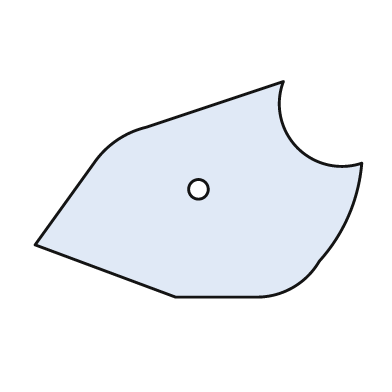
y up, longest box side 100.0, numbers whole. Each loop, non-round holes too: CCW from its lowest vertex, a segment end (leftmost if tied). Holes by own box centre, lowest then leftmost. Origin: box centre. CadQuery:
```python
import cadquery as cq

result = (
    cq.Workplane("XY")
    .moveTo(-7.0, -33.0)
    .lineTo(18.0, -33.0)
    .threePointArc((29.0, -30.0), (37.0, -22.0))
    .threePointArc((46.0, -8.0), (50.0, 8.0))
    .threePointArc((30.0, 13.0), (26.0, 33.0))
    .lineTo(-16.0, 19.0)
    .threePointArc((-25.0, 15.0), (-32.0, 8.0))
    .lineTo(-50.0, -17.0)
    .close()
    .moveTo(0.0, 0.0)
    .circle(3.0)
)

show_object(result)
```